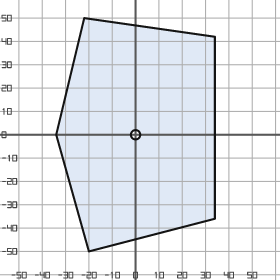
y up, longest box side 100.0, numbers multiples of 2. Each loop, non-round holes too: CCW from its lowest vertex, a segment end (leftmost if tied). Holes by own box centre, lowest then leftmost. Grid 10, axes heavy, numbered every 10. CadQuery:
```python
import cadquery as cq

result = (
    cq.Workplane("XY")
    .moveTo(-20.0, -50.0)
    .lineTo(34.0, -36.0)
    .lineTo(34.0, 42.0)
    .lineTo(-22.0, 50.0)
    .lineTo(-34.0, 0.0)
    .close()
    .moveTo(0.0, 0.0)
    .circle(2.0)
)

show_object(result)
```